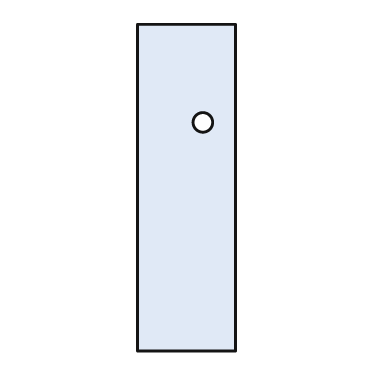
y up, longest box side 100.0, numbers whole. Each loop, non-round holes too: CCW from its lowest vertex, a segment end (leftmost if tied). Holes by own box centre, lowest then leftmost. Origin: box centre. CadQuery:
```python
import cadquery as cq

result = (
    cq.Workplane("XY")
    .moveTo(-15.0, -50.0)
    .lineTo(15.0, -50.0)
    .lineTo(15.0, 50.0)
    .lineTo(-15.0, 50.0)
    .close()
    .moveTo(5.0, 20.0)
    .circle(3.0)
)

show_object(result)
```